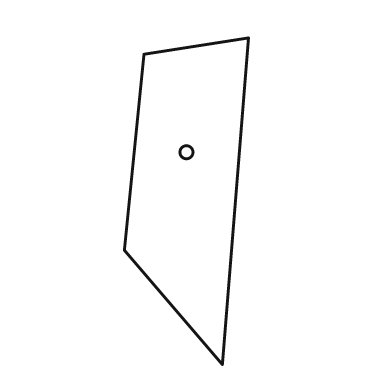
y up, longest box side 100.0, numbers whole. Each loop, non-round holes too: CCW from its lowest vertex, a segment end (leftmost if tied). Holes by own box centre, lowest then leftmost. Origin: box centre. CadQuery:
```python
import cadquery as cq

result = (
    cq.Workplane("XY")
    .moveTo(11.0, -50.0)
    .lineTo(19.0, 50.0)
    .lineTo(-13.0, 45.0)
    .lineTo(-19.0, -15.0)
    .close()
    .moveTo(0.0, 15.0)
    .circle(2.0)
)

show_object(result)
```